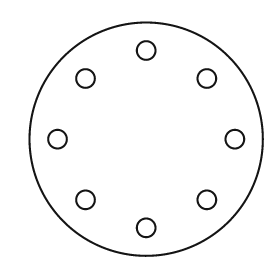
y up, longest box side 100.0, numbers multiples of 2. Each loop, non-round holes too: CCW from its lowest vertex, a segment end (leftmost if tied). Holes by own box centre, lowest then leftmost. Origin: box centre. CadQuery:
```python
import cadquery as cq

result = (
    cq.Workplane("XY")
    .moveTo(0.0, 0.0)
    .circle(50.0)
    .moveTo(0.0, -38.0)
    .circle(4.0)
    .moveTo(-26.0, -26.0)
    .circle(4.0)
    .moveTo(26.0, -26.0)
    .circle(4.0)
    .moveTo(-38.0, 0.0)
    .circle(4.0)
    .moveTo(38.0, 0.0)
    .circle(4.0)
    .moveTo(-26.0, 26.0)
    .circle(4.0)
    .moveTo(26.0, 26.0)
    .circle(4.0)
    .moveTo(0.0, 38.0)
    .circle(4.0)
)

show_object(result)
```